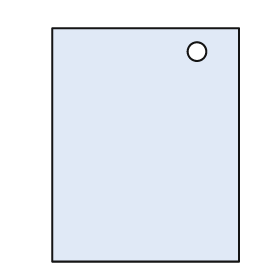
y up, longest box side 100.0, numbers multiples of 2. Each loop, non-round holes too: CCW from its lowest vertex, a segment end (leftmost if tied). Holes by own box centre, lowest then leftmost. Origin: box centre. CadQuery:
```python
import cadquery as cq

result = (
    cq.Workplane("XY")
    .moveTo(-40.0, -50.0)
    .lineTo(40.0, -50.0)
    .lineTo(40.0, 50.0)
    .lineTo(-40.0, 50.0)
    .close()
    .moveTo(22.0, 40.0)
    .circle(4.0)
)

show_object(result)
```